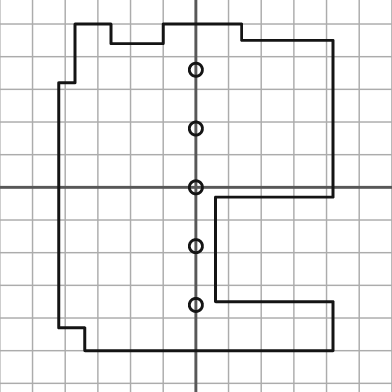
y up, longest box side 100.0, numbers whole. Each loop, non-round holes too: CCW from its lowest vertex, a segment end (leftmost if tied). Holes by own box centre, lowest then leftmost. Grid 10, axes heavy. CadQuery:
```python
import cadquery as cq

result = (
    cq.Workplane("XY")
    .moveTo(-34.0, -50.0)
    .lineTo(42.0, -50.0)
    .lineTo(42.0, -35.0)
    .lineTo(6.0, -35.0)
    .lineTo(6.0, -3.0)
    .lineTo(42.0, -3.0)
    .lineTo(42.0, 45.0)
    .lineTo(14.0, 45.0)
    .lineTo(14.0, 50.0)
    .lineTo(-10.0, 50.0)
    .lineTo(-10.0, 44.0)
    .lineTo(-26.0, 44.0)
    .lineTo(-26.0, 50.0)
    .lineTo(-37.0, 50.0)
    .lineTo(-37.0, 32.0)
    .lineTo(-42.0, 32.0)
    .lineTo(-42.0, -43.0)
    .lineTo(-34.0, -43.0)
    .close()
    .moveTo(0.0, -36.0)
    .circle(2.0)
    .moveTo(0.0, -18.0)
    .circle(2.0)
    .moveTo(0.0, 0.0)
    .circle(2.0)
    .moveTo(0.0, 18.0)
    .circle(2.0)
    .moveTo(0.0, 36.0)
    .circle(2.0)
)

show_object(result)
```